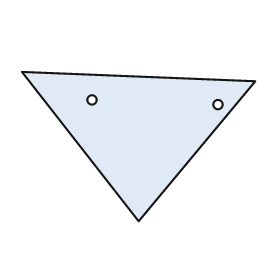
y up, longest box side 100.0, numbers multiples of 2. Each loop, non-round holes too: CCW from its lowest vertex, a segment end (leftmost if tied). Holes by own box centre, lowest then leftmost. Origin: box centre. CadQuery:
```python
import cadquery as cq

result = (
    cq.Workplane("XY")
    .moveTo(0.0, -32.0)
    .lineTo(50.0, 28.0)
    .lineTo(-50.0, 32.0)
    .close()
    .moveTo(34.0, 18.0)
    .circle(2.0)
    .moveTo(-20.0, 20.0)
    .circle(2.0)
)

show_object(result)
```